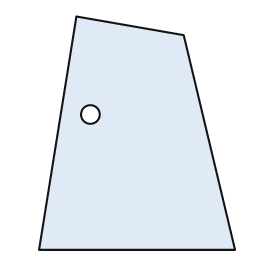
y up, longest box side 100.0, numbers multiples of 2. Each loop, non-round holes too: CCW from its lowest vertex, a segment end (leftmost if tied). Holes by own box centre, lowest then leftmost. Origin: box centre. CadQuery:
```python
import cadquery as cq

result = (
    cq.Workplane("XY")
    .moveTo(-42.0, -50.0)
    .lineTo(42.0, -50.0)
    .lineTo(20.0, 42.0)
    .lineTo(-26.0, 50.0)
    .close()
    .moveTo(-20.0, 8.0)
    .circle(4.0)
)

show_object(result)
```